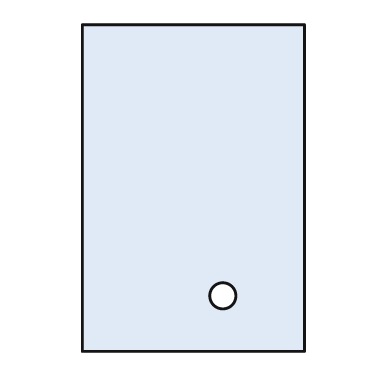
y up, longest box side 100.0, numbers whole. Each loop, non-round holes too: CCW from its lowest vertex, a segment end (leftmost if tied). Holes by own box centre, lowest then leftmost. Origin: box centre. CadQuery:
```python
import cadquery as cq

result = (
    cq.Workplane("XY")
    .moveTo(-34.0, -50.0)
    .lineTo(34.0, -50.0)
    .lineTo(34.0, 50.0)
    .lineTo(-34.0, 50.0)
    .close()
    .moveTo(9.0, -33.0)
    .circle(4.0)
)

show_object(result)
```